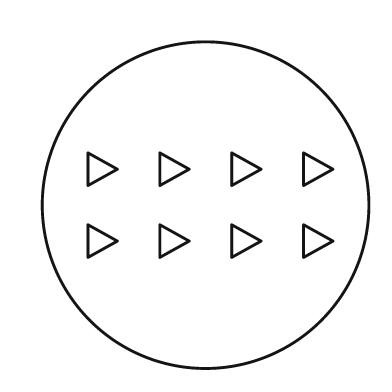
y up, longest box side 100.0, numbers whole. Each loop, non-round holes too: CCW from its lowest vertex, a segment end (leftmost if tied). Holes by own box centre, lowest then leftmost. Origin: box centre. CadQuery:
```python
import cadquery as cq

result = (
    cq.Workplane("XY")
    .moveTo(0.0, 0.0)
    .circle(50.0)
    .moveTo(-36.0, -16.0)
    .lineTo(-27.0, -11.0)
    .lineTo(-36.0, -6.0)
    .close()
    .moveTo(-14.0, -16.0)
    .lineTo(-5.0, -11.0)
    .lineTo(-14.0, -6.0)
    .close()
    .moveTo(8.0, -16.0)
    .lineTo(17.0, -11.0)
    .lineTo(8.0, -6.0)
    .close()
    .moveTo(30.0, -16.0)
    .lineTo(39.0, -11.0)
    .lineTo(30.0, -6.0)
    .close()
    .moveTo(-36.0, 6.0)
    .lineTo(-27.0, 11.0)
    .lineTo(-36.0, 16.0)
    .close()
    .moveTo(-14.0, 6.0)
    .lineTo(-5.0, 11.0)
    .lineTo(-14.0, 16.0)
    .close()
    .moveTo(8.0, 6.0)
    .lineTo(17.0, 11.0)
    .lineTo(8.0, 16.0)
    .close()
    .moveTo(30.0, 6.0)
    .lineTo(39.0, 11.0)
    .lineTo(30.0, 16.0)
    .close()
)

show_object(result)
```